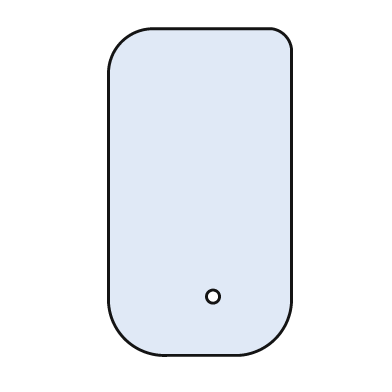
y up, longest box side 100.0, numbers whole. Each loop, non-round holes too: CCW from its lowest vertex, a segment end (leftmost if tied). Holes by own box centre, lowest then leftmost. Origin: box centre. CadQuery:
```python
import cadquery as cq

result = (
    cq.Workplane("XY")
    .moveTo(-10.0, -50.0)
    .lineTo(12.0, -50.0)
    .threePointArc((23.0, -45.0), (28.0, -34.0))
    .lineTo(28.0, 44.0)
    .threePointArc((26.0, 48.0), (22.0, 50.0))
    .lineTo(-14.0, 50.0)
    .threePointArc((-24.0, 46.0), (-28.0, 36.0))
    .lineTo(-28.0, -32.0)
    .threePointArc((-23.0, -45.0), (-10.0, -50.0))
    .close()
    .moveTo(4.0, -32.0)
    .circle(2.0)
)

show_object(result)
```